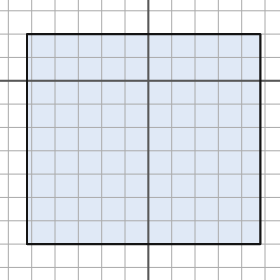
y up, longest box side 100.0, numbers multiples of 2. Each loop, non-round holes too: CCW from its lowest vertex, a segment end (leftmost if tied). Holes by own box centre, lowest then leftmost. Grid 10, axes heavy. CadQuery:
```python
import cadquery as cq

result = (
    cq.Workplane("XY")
    .moveTo(-52.0, -70.0)
    .lineTo(48.0, -70.0)
    .lineTo(48.0, 20.0)
    .lineTo(-52.0, 20.0)
    .close()
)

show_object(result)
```